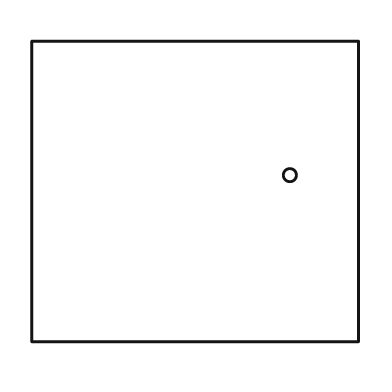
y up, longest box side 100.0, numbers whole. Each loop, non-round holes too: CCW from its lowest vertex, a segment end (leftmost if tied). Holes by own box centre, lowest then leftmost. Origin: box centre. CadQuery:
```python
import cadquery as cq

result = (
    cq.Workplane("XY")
    .moveTo(-50.0, -46.0)
    .lineTo(50.0, -46.0)
    .lineTo(50.0, 46.0)
    .lineTo(-50.0, 46.0)
    .close()
    .moveTo(29.0, 5.0)
    .circle(2.0)
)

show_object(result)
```